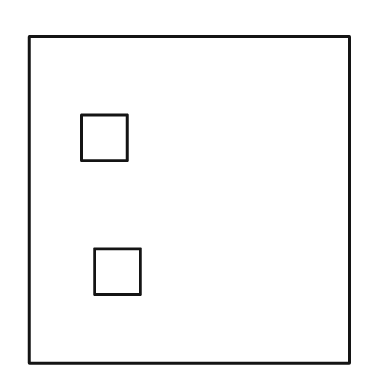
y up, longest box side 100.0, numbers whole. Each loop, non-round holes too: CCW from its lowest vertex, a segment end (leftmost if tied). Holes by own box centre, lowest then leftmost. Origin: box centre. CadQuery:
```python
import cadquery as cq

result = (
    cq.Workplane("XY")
    .moveTo(-49.0, -50.0)
    .lineTo(49.0, -50.0)
    .lineTo(49.0, 50.0)
    .lineTo(-49.0, 50.0)
    .close()
    .moveTo(-29.0, -29.0)
    .lineTo(-15.0, -29.0)
    .lineTo(-15.0, -15.0)
    .lineTo(-29.0, -15.0)
    .close()
    .moveTo(-33.0, 12.0)
    .lineTo(-19.0, 12.0)
    .lineTo(-19.0, 26.0)
    .lineTo(-33.0, 26.0)
    .close()
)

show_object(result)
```